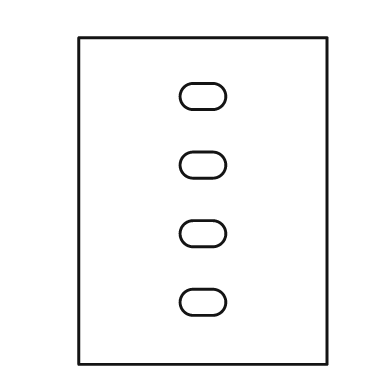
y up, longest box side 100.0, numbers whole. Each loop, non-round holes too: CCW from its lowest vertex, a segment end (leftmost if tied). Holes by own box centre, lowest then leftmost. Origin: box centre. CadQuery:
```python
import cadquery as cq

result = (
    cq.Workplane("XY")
    .moveTo(-38.0, -50.0)
    .lineTo(38.0, -50.0)
    .lineTo(38.0, 50.0)
    .lineTo(-38.0, 50.0)
    .close()
    .moveTo(-3.0, -35.0)
    .lineTo(3.0, -35.0)
    .threePointArc((7.0, -31.0), (3.0, -27.0))
    .lineTo(-3.0, -27.0)
    .threePointArc((-7.0, -31.0), (-3.0, -35.0))
    .close()
    .moveTo(-3.0, -14.0)
    .lineTo(3.0, -14.0)
    .threePointArc((7.0, -10.0), (3.0, -6.0))
    .lineTo(-3.0, -6.0)
    .threePointArc((-7.0, -10.0), (-3.0, -14.0))
    .close()
    .moveTo(-3.0, 7.0)
    .lineTo(3.0, 7.0)
    .threePointArc((7.0, 11.0), (3.0, 15.0))
    .lineTo(-3.0, 15.0)
    .threePointArc((-7.0, 11.0), (-3.0, 7.0))
    .close()
    .moveTo(-3.0, 28.0)
    .lineTo(3.0, 28.0)
    .threePointArc((7.0, 32.0), (3.0, 36.0))
    .lineTo(-3.0, 36.0)
    .threePointArc((-7.0, 32.0), (-3.0, 28.0))
    .close()
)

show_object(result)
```